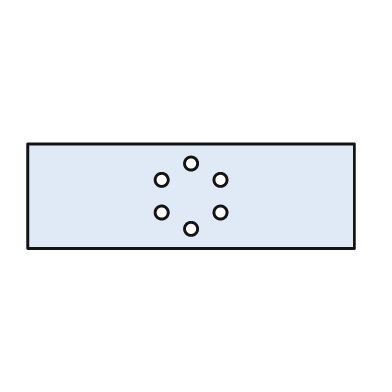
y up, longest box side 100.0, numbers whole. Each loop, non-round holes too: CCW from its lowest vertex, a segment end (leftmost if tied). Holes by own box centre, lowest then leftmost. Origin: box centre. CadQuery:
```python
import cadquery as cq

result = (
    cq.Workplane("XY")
    .moveTo(-50.0, -16.0)
    .lineTo(50.0, -16.0)
    .lineTo(50.0, 16.0)
    .lineTo(-50.0, 16.0)
    .close()
    .moveTo(0.0, -10.0)
    .circle(2.0)
    .moveTo(-9.0, -5.0)
    .circle(2.0)
    .moveTo(9.0, -5.0)
    .circle(2.0)
    .moveTo(-9.0, 5.0)
    .circle(2.0)
    .moveTo(9.0, 5.0)
    .circle(2.0)
    .moveTo(0.0, 10.0)
    .circle(2.0)
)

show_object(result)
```